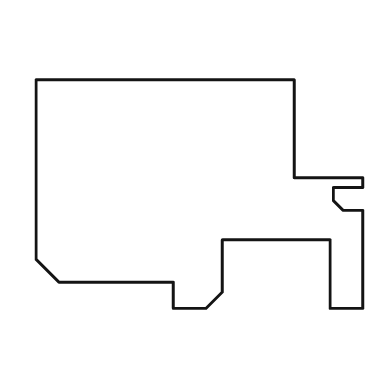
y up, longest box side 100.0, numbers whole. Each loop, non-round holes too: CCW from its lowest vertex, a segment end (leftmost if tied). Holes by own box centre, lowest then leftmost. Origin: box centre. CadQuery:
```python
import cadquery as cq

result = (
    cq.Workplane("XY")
    .moveTo(-8.0, -35.0)
    .lineTo(2.0, -35.0)
    .lineTo(7.0, -30.0)
    .lineTo(7.0, -14.0)
    .lineTo(40.0, -14.0)
    .lineTo(40.0, -35.0)
    .lineTo(50.0, -35.0)
    .lineTo(50.0, -5.0)
    .lineTo(44.0, -5.0)
    .lineTo(41.0, -2.0)
    .lineTo(41.0, 2.0)
    .lineTo(50.0, 2.0)
    .lineTo(50.0, 5.0)
    .lineTo(29.0, 5.0)
    .lineTo(29.0, 35.0)
    .lineTo(-50.0, 35.0)
    .lineTo(-50.0, -20.0)
    .lineTo(-43.0, -27.0)
    .lineTo(-8.0, -27.0)
    .close()
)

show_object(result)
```